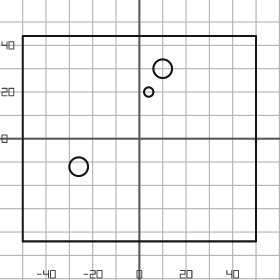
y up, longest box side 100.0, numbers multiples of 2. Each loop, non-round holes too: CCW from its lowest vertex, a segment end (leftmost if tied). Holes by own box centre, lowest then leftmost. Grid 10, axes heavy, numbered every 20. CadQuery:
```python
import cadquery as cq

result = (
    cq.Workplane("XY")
    .moveTo(-50.0, -44.0)
    .lineTo(50.0, -44.0)
    .lineTo(50.0, 44.0)
    .lineTo(-50.0, 44.0)
    .close()
    .moveTo(-26.0, -12.0)
    .circle(4.0)
    .moveTo(4.0, 20.0)
    .circle(2.0)
    .moveTo(10.0, 30.0)
    .circle(4.0)
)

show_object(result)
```